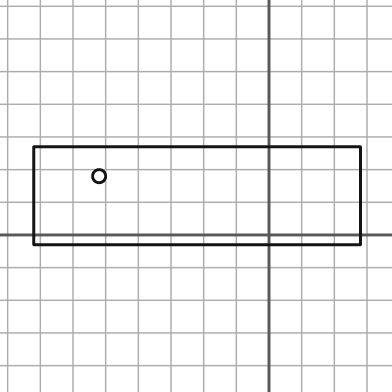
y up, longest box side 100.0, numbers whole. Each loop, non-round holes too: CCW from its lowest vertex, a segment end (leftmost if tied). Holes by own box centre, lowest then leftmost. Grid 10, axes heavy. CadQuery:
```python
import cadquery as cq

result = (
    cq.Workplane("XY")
    .moveTo(-72.0, -3.0)
    .lineTo(28.0, -3.0)
    .lineTo(28.0, 27.0)
    .lineTo(-72.0, 27.0)
    .close()
    .moveTo(-52.0, 18.0)
    .circle(2.0)
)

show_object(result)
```